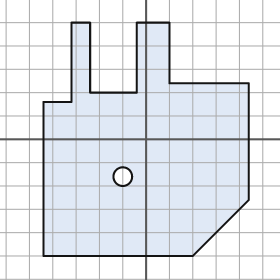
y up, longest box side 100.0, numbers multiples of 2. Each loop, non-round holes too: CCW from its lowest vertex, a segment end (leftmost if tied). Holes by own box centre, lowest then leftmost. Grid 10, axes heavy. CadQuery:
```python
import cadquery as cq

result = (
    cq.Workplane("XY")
    .moveTo(-44.0, -50.0)
    .lineTo(20.0, -50.0)
    .lineTo(44.0, -26.0)
    .lineTo(44.0, 24.0)
    .lineTo(10.0, 24.0)
    .lineTo(10.0, 50.0)
    .lineTo(-4.0, 50.0)
    .lineTo(-4.0, 20.0)
    .lineTo(-24.0, 20.0)
    .lineTo(-24.0, 50.0)
    .lineTo(-32.0, 50.0)
    .lineTo(-32.0, 16.0)
    .lineTo(-44.0, 16.0)
    .close()
    .moveTo(-10.0, -16.0)
    .circle(4.0)
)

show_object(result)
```